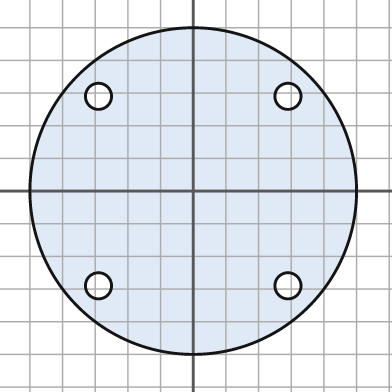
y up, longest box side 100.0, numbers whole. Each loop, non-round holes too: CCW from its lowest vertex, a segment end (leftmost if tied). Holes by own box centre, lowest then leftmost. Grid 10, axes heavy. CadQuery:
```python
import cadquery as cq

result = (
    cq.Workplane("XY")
    .moveTo(0.0, 0.0)
    .circle(50.0)
    .moveTo(-29.0, -29.0)
    .circle(4.0)
    .moveTo(29.0, -29.0)
    .circle(4.0)
    .moveTo(-29.0, 29.0)
    .circle(4.0)
    .moveTo(29.0, 29.0)
    .circle(4.0)
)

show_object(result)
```